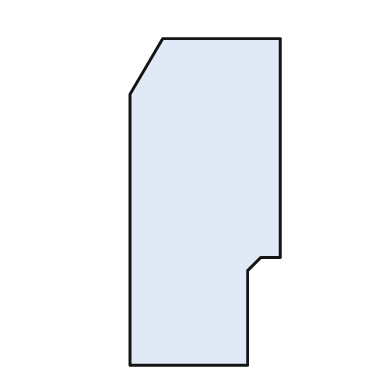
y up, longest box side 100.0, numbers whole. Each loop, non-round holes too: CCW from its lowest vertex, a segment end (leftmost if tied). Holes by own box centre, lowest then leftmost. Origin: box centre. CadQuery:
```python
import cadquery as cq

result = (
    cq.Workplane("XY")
    .moveTo(-23.0, -50.0)
    .lineTo(13.0, -50.0)
    .lineTo(13.0, -21.0)
    .lineTo(17.0, -17.0)
    .lineTo(23.0, -17.0)
    .lineTo(23.0, 50.0)
    .lineTo(-13.0, 50.0)
    .lineTo(-23.0, 33.0)
    .close()
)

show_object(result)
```